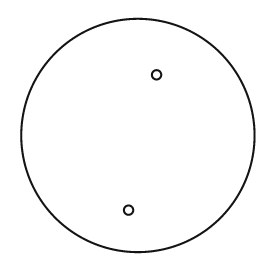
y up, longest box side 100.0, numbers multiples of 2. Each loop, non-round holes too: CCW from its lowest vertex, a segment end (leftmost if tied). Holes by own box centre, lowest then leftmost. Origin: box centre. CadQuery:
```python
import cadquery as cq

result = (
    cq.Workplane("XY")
    .moveTo(0.0, 0.0)
    .circle(50.0)
    .moveTo(-4.0, -32.0)
    .circle(2.0)
    .moveTo(8.0, 26.0)
    .circle(2.0)
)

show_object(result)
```